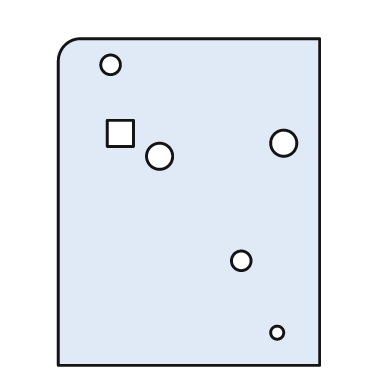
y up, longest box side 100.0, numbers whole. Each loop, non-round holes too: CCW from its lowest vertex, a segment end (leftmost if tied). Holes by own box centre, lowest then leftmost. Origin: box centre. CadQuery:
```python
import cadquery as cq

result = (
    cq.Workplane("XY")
    .moveTo(-40.0, -50.0)
    .lineTo(40.0, -50.0)
    .lineTo(40.0, 50.0)
    .lineTo(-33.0, 50.0)
    .threePointArc((-38.0, 48.0), (-40.0, 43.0))
    .close()
    .moveTo(27.0, -40.0)
    .circle(2.0)
    .moveTo(16.0, -18.0)
    .circle(3.0)
    .moveTo(-9.0, 14.0)
    .circle(4.0)
    .moveTo(29.0, 18.0)
    .circle(4.0)
    .moveTo(-25.0, 17.0)
    .lineTo(-17.0, 17.0)
    .lineTo(-17.0, 25.0)
    .lineTo(-25.0, 25.0)
    .close()
    .moveTo(-24.0, 42.0)
    .circle(3.0)
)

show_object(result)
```